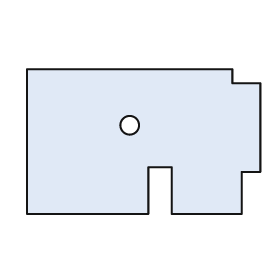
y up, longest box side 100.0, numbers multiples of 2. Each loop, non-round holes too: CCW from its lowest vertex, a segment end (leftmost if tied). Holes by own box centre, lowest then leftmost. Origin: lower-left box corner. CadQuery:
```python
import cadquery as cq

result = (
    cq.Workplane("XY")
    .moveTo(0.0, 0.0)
    .lineTo(52.0, 0.0)
    .lineTo(52.0, 20.0)
    .lineTo(62.0, 20.0)
    .lineTo(62.0, 0.0)
    .lineTo(92.0, 0.0)
    .lineTo(92.0, 18.0)
    .lineTo(100.0, 18.0)
    .lineTo(100.0, 56.0)
    .lineTo(88.0, 56.0)
    .lineTo(88.0, 62.0)
    .lineTo(0.0, 62.0)
    .close()
    .moveTo(44.0, 38.0)
    .circle(4.0)
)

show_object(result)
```